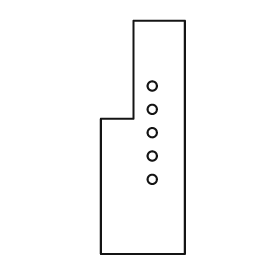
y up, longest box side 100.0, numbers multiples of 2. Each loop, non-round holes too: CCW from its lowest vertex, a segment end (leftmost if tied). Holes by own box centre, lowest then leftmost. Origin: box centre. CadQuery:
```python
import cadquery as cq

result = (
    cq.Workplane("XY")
    .moveTo(-18.0, -50.0)
    .lineTo(18.0, -50.0)
    .lineTo(18.0, 50.0)
    .lineTo(-4.0, 50.0)
    .lineTo(-4.0, 8.0)
    .lineTo(-18.0, 8.0)
    .close()
    .moveTo(4.0, -18.0)
    .circle(2.0)
    .moveTo(4.0, -8.0)
    .circle(2.0)
    .moveTo(4.0, 2.0)
    .circle(2.0)
    .moveTo(4.0, 12.0)
    .circle(2.0)
    .moveTo(4.0, 22.0)
    .circle(2.0)
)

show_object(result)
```